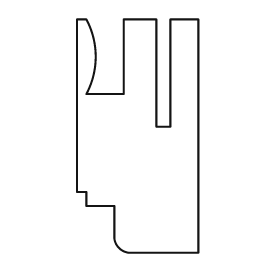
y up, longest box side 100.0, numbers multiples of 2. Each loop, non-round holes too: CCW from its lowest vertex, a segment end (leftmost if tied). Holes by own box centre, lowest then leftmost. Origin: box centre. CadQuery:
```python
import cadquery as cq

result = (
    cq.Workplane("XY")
    .moveTo(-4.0, -50.0)
    .lineTo(26.0, -50.0)
    .lineTo(26.0, 50.0)
    .lineTo(14.0, 50.0)
    .lineTo(14.0, 4.0)
    .lineTo(8.0, 4.0)
    .lineTo(8.0, 50.0)
    .lineTo(-6.0, 50.0)
    .lineTo(-6.0, 18.0)
    .lineTo(-22.0, 18.0)
    .threePointArc((-18.0, 34.0), (-22.0, 50.0))
    .lineTo(-26.0, 50.0)
    .lineTo(-26.0, -24.0)
    .lineTo(-22.0, -24.0)
    .lineTo(-22.0, -30.0)
    .lineTo(-10.0, -30.0)
    .lineTo(-10.0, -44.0)
    .threePointArc((-8.0, -48.0), (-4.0, -50.0))
    .close()
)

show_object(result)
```